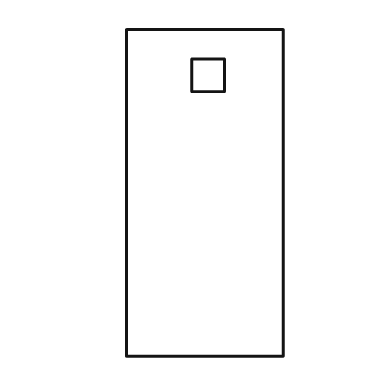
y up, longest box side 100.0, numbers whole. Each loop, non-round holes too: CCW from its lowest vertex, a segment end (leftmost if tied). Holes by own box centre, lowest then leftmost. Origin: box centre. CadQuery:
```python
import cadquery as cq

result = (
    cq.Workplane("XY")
    .moveTo(-24.0, -50.0)
    .lineTo(24.0, -50.0)
    .lineTo(24.0, 50.0)
    .lineTo(-24.0, 50.0)
    .close()
    .moveTo(-4.0, 31.0)
    .lineTo(6.0, 31.0)
    .lineTo(6.0, 41.0)
    .lineTo(-4.0, 41.0)
    .close()
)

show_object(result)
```